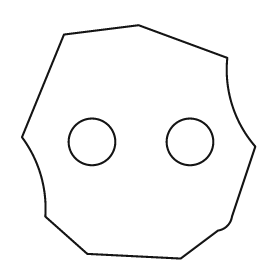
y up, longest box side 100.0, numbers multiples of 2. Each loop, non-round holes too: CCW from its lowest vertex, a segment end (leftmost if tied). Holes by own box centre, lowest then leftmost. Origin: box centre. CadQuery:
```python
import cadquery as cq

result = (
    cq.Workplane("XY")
    .moveTo(18.0, -50.0)
    .lineTo(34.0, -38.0)
    .threePointArc((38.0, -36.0), (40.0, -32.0))
    .lineTo(50.0, -2.0)
    .threePointArc((40.0, 16.0), (38.0, 36.0))
    .lineTo(0.0, 50.0)
    .lineTo(-32.0, 46.0)
    .lineTo(-50.0, 2.0)
    .threePointArc((-42.0, -14.0), (-40.0, -32.0))
    .lineTo(-22.0, -48.0)
    .close()
    .moveTo(-20.0, 0.0)
    .circle(10.0)
    .moveTo(22.0, 0.0)
    .circle(10.0)
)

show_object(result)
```